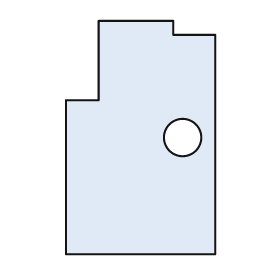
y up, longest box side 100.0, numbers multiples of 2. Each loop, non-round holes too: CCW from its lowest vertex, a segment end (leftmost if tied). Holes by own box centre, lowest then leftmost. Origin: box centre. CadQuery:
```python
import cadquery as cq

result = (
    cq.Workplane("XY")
    .moveTo(-32.0, -50.0)
    .lineTo(32.0, -50.0)
    .lineTo(32.0, 44.0)
    .lineTo(14.0, 44.0)
    .lineTo(14.0, 50.0)
    .lineTo(-18.0, 50.0)
    .lineTo(-18.0, 16.0)
    .lineTo(-32.0, 16.0)
    .close()
    .moveTo(18.0, 0.0)
    .circle(8.0)
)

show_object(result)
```